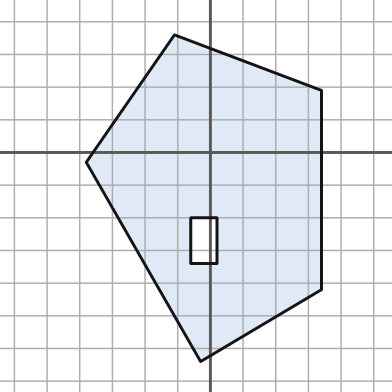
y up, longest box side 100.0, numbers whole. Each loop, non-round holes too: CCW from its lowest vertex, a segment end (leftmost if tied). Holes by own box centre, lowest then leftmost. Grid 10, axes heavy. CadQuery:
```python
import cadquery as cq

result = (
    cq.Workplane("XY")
    .moveTo(-3.0, -64.0)
    .lineTo(34.0, -42.0)
    .lineTo(34.0, 19.0)
    .lineTo(-11.0, 36.0)
    .lineTo(-38.0, -3.0)
    .close()
    .moveTo(-6.0, -34.0)
    .lineTo(2.0, -34.0)
    .lineTo(2.0, -20.0)
    .lineTo(-6.0, -20.0)
    .close()
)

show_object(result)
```